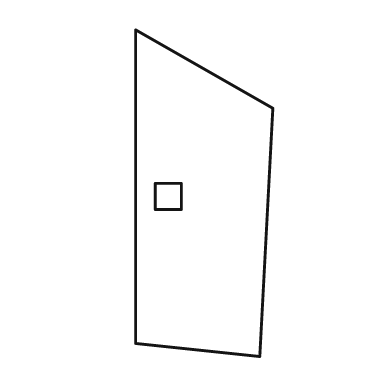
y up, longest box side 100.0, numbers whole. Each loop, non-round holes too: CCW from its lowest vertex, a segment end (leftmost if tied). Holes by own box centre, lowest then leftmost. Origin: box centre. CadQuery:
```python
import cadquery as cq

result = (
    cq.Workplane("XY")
    .moveTo(17.0, -50.0)
    .lineTo(21.0, 26.0)
    .lineTo(-21.0, 50.0)
    .lineTo(-21.0, -46.0)
    .close()
    .moveTo(-15.0, -5.0)
    .lineTo(-7.0, -5.0)
    .lineTo(-7.0, 3.0)
    .lineTo(-15.0, 3.0)
    .close()
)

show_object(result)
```